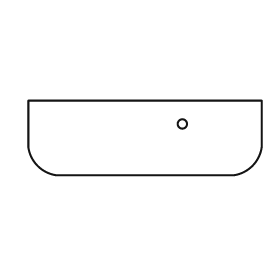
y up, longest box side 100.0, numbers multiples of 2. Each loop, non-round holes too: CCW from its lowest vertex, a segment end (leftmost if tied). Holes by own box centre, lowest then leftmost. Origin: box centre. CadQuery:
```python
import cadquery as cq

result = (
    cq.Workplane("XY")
    .moveTo(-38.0, -16.0)
    .lineTo(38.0, -16.0)
    .threePointArc((46.0, -12.0), (50.0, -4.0))
    .lineTo(50.0, 16.0)
    .lineTo(-50.0, 16.0)
    .lineTo(-50.0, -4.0)
    .threePointArc((-46.0, -12.0), (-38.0, -16.0))
    .close()
    .moveTo(16.0, 6.0)
    .circle(2.0)
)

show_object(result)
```